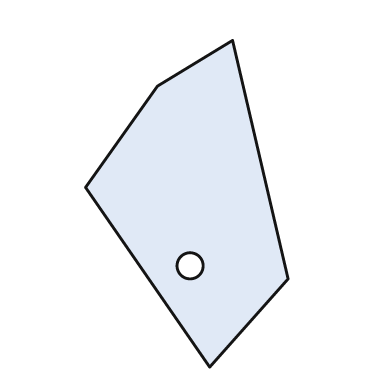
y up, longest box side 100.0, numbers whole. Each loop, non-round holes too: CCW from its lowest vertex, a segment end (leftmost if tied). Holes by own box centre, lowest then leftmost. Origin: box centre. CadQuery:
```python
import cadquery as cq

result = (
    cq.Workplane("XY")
    .moveTo(7.0, -50.0)
    .lineTo(31.0, -23.0)
    .lineTo(14.0, 50.0)
    .lineTo(-9.0, 36.0)
    .lineTo(-31.0, 5.0)
    .close()
    .moveTo(1.0, -19.0)
    .circle(4.0)
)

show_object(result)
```